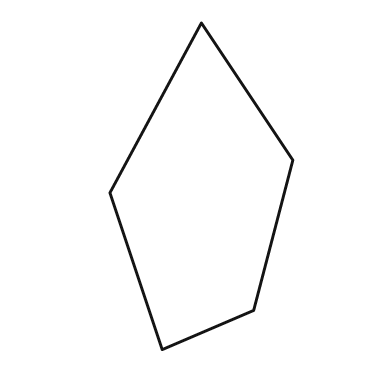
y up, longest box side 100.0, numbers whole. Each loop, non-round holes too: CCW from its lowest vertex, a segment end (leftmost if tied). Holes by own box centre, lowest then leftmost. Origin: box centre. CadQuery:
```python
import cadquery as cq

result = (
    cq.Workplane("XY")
    .moveTo(-12.0, -50.0)
    .lineTo(16.0, -38.0)
    .lineTo(28.0, 8.0)
    .lineTo(0.0, 50.0)
    .lineTo(-28.0, -2.0)
    .close()
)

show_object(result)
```